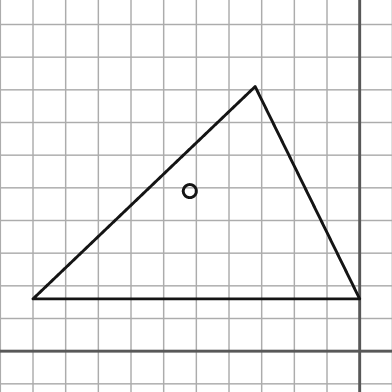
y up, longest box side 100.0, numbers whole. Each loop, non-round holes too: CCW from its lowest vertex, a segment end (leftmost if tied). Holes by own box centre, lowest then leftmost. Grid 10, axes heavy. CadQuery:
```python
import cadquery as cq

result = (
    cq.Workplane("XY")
    .moveTo(-100.0, 16.0)
    .lineTo(0.0, 16.0)
    .lineTo(-32.0, 81.0)
    .close()
    .moveTo(-52.0, 49.0)
    .circle(2.0)
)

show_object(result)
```